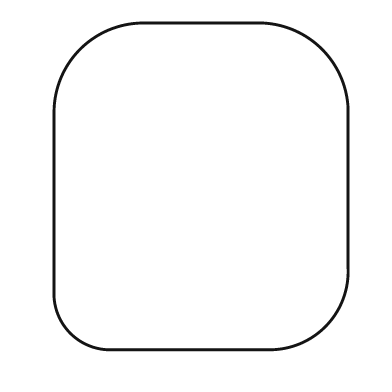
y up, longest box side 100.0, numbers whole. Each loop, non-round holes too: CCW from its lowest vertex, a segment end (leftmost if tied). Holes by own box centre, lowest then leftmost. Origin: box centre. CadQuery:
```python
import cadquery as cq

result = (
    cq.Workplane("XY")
    .moveTo(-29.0, -50.0)
    .lineTo(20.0, -50.0)
    .threePointArc((38.0, -43.0), (45.0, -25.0))
    .lineTo(45.0, 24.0)
    .threePointArc((37.0, 42.0), (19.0, 50.0))
    .lineTo(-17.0, 50.0)
    .threePointArc((-37.0, 42.0), (-45.0, 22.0))
    .lineTo(-45.0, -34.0)
    .threePointArc((-40.0, -45.0), (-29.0, -50.0))
    .close()
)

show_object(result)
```